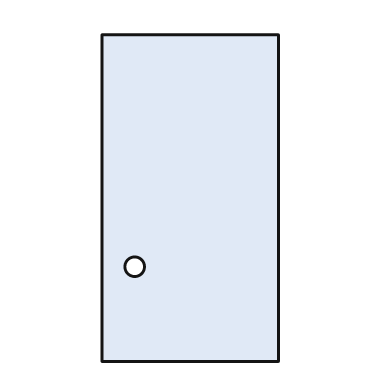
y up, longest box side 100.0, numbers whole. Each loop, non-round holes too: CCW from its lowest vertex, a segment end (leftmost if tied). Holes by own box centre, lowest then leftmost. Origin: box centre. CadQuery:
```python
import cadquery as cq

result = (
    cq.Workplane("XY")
    .moveTo(-27.0, -50.0)
    .lineTo(27.0, -50.0)
    .lineTo(27.0, 50.0)
    .lineTo(-27.0, 50.0)
    .close()
    .moveTo(-17.0, -21.0)
    .circle(3.0)
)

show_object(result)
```